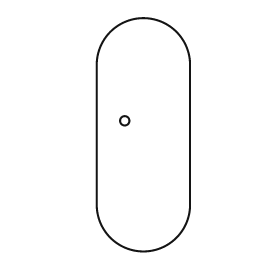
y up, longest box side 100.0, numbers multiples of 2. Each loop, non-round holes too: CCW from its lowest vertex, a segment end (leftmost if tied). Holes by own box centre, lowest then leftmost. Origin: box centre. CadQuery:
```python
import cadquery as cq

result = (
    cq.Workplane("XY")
    .moveTo(-20.0, -30.0)
    .threePointArc((0.0, -50.0), (20.0, -30.0))
    .lineTo(20.0, 30.0)
    .threePointArc((0.0, 50.0), (-20.0, 30.0))
    .close()
    .moveTo(-8.0, 6.0)
    .circle(2.0)
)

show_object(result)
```